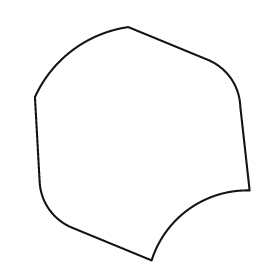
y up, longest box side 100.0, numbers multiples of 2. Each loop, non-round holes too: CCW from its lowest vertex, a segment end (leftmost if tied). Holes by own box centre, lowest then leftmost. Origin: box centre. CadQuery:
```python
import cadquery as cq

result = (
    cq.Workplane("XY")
    .moveTo(4.0, -50.0)
    .threePointArc((20.0, -28.0), (46.0, -20.0))
    .lineTo(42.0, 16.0)
    .threePointArc((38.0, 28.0), (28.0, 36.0))
    .lineTo(-6.0, 50.0)
    .threePointArc((-30.0, 40.0), (-46.0, 20.0))
    .lineTo(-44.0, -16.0)
    .threePointArc((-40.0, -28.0), (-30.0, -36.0))
    .close()
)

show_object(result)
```